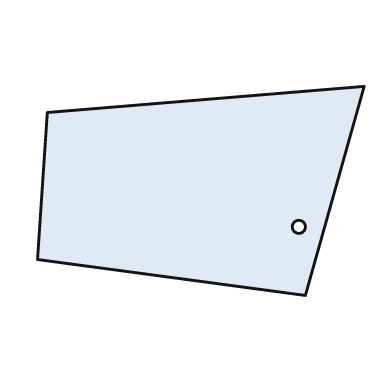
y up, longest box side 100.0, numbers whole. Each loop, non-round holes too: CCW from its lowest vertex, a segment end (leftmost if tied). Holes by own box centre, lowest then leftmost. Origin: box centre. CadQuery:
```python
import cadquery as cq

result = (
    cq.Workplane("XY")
    .moveTo(32.0, -32.0)
    .lineTo(50.0, 32.0)
    .lineTo(-47.0, 24.0)
    .lineTo(-50.0, -21.0)
    .close()
    .moveTo(30.0, -11.0)
    .circle(2.0)
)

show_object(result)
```